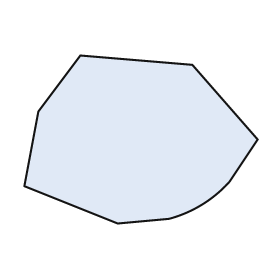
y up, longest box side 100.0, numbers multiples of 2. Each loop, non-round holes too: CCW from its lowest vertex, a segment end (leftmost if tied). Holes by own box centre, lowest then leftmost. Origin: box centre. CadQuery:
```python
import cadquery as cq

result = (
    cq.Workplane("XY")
    .moveTo(-10.0, -36.0)
    .lineTo(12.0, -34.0)
    .threePointArc((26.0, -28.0), (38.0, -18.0))
    .lineTo(50.0, 0.0)
    .lineTo(22.0, 32.0)
    .lineTo(-26.0, 36.0)
    .lineTo(-44.0, 12.0)
    .lineTo(-50.0, -20.0)
    .close()
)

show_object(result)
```